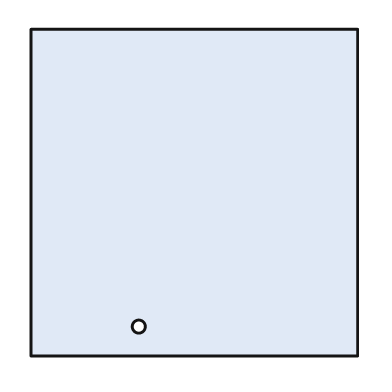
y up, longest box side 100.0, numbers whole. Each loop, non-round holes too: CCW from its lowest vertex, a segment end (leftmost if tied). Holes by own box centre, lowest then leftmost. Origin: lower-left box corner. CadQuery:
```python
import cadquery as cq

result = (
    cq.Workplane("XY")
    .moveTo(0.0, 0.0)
    .lineTo(100.0, 0.0)
    .lineTo(100.0, 100.0)
    .lineTo(0.0, 100.0)
    .close()
    .moveTo(33.0, 9.0)
    .circle(2.0)
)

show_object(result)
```